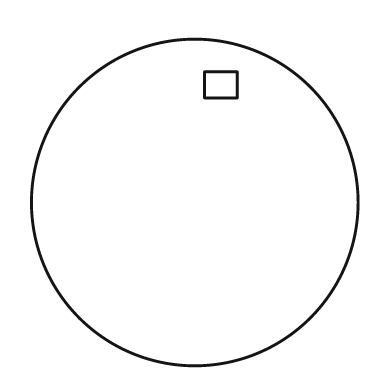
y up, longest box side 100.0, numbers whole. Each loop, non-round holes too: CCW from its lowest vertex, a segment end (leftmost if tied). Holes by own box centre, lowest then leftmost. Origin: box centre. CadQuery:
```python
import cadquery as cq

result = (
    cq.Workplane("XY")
    .moveTo(0.0, 0.0)
    .circle(50.0)
    .moveTo(3.0, 32.0)
    .lineTo(13.0, 32.0)
    .lineTo(13.0, 40.0)
    .lineTo(3.0, 40.0)
    .close()
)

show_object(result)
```